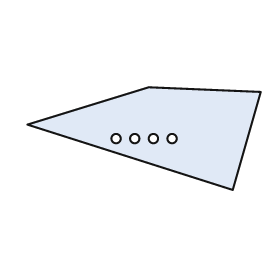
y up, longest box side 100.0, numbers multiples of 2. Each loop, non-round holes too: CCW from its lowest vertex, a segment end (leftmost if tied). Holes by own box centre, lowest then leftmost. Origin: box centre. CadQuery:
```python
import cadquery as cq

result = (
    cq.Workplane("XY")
    .moveTo(38.0, -22.0)
    .lineTo(50.0, 20.0)
    .lineTo(2.0, 22.0)
    .lineTo(-50.0, 6.0)
    .close()
    .moveTo(-12.0, 0.0)
    .circle(2.0)
    .moveTo(-4.0, 0.0)
    .circle(2.0)
    .moveTo(4.0, 0.0)
    .circle(2.0)
    .moveTo(12.0, 0.0)
    .circle(2.0)
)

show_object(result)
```